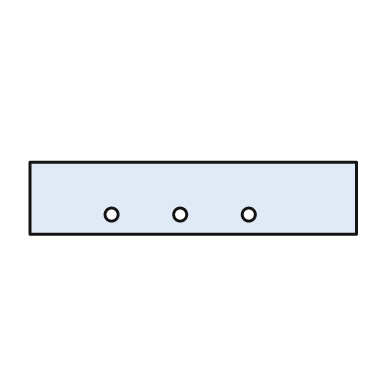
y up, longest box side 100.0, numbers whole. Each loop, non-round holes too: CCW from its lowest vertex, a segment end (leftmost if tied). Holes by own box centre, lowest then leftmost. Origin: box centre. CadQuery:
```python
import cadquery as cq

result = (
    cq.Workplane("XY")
    .moveTo(-50.0, -11.0)
    .lineTo(50.0, -11.0)
    .lineTo(50.0, 11.0)
    .lineTo(-50.0, 11.0)
    .close()
    .moveTo(-25.0, -5.0)
    .circle(2.0)
    .moveTo(-4.0, -5.0)
    .circle(2.0)
    .moveTo(17.0, -5.0)
    .circle(2.0)
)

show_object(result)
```